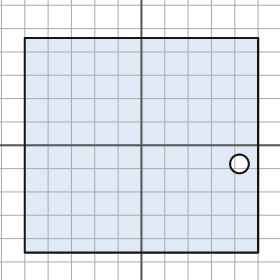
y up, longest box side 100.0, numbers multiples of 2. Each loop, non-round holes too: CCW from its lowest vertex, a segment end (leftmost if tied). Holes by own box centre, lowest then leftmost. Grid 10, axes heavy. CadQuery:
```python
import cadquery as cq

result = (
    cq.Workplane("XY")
    .moveTo(-50.0, -46.0)
    .lineTo(50.0, -46.0)
    .lineTo(50.0, 46.0)
    .lineTo(-50.0, 46.0)
    .close()
    .moveTo(42.0, -8.0)
    .circle(4.0)
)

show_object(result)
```